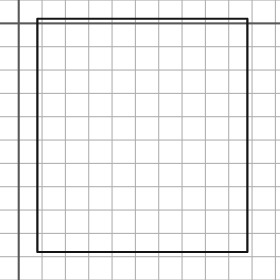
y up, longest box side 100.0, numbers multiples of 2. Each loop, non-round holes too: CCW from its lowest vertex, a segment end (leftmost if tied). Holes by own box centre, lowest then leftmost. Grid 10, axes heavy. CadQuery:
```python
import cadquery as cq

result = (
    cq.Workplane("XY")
    .moveTo(8.0, -98.0)
    .lineTo(98.0, -98.0)
    .lineTo(98.0, 2.0)
    .lineTo(8.0, 2.0)
    .close()
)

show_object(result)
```